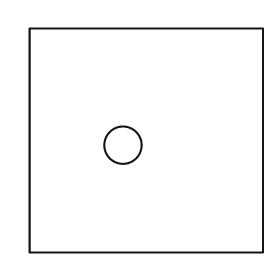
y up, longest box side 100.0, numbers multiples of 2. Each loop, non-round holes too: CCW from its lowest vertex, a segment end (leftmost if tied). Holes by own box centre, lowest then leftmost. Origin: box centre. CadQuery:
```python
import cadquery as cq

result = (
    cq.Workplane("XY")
    .moveTo(-50.0, -48.0)
    .lineTo(50.0, -48.0)
    .lineTo(50.0, 48.0)
    .lineTo(-50.0, 48.0)
    .close()
    .moveTo(-10.0, -2.0)
    .circle(8.0)
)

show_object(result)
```